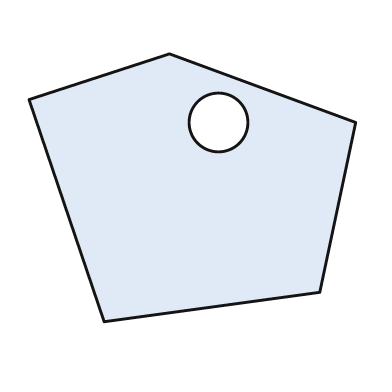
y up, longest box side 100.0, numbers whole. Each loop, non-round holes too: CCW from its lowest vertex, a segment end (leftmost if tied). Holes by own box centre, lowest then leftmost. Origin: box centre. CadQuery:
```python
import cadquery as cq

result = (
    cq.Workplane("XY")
    .moveTo(-27.0, -41.0)
    .lineTo(39.0, -32.0)
    .lineTo(50.0, 20.0)
    .lineTo(-7.0, 41.0)
    .lineTo(-50.0, 27.0)
    .close()
    .moveTo(8.0, 20.0)
    .circle(9.0)
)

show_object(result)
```